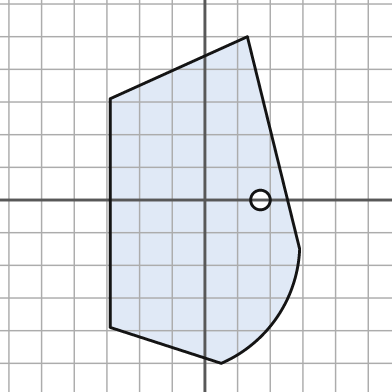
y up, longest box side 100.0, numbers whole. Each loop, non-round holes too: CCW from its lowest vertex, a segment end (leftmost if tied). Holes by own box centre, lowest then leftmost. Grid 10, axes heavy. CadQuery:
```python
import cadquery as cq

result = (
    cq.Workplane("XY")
    .moveTo(5.0, -50.0)
    .threePointArc((22.0, -36.0), (29.0, -15.0))
    .lineTo(13.0, 50.0)
    .lineTo(-29.0, 31.0)
    .lineTo(-29.0, -39.0)
    .close()
    .moveTo(17.0, 0.0)
    .circle(3.0)
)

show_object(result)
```